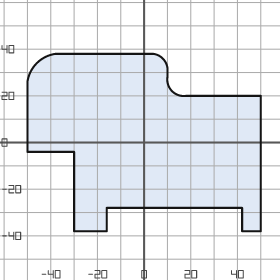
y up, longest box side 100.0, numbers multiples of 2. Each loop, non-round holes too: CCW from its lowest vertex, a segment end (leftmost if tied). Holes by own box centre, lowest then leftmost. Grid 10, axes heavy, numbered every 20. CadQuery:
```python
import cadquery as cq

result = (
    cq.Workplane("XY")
    .moveTo(-30.0, -38.0)
    .lineTo(-16.0, -38.0)
    .lineTo(-16.0, -28.0)
    .lineTo(42.0, -28.0)
    .lineTo(42.0, -38.0)
    .lineTo(50.0, -38.0)
    .lineTo(50.0, 20.0)
    .lineTo(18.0, 20.0)
    .threePointArc((12.0, 22.0), (10.0, 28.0))
    .lineTo(10.0, 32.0)
    .threePointArc((8.0, 36.0), (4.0, 38.0))
    .lineTo(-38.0, 38.0)
    .threePointArc((-46.0, 34.0), (-50.0, 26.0))
    .lineTo(-50.0, -4.0)
    .lineTo(-30.0, -4.0)
    .close()
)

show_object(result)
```